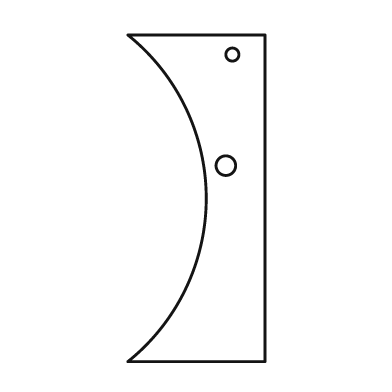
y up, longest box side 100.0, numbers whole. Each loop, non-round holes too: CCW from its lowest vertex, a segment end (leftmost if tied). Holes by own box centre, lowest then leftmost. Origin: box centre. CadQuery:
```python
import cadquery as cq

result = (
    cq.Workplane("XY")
    .moveTo(-21.0, -50.0)
    .lineTo(21.0, -50.0)
    .lineTo(21.0, 50.0)
    .lineTo(-21.0, 50.0)
    .threePointArc((3.0, 0.0), (-21.0, -50.0))
    .close()
    .moveTo(9.0, 10.0)
    .circle(3.0)
    .moveTo(11.0, 44.0)
    .circle(2.0)
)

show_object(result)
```